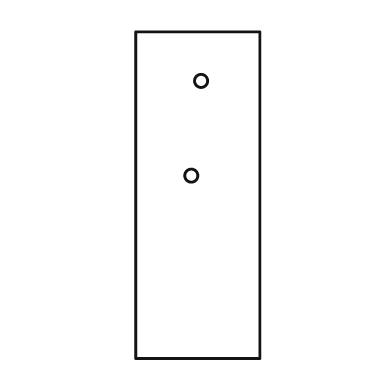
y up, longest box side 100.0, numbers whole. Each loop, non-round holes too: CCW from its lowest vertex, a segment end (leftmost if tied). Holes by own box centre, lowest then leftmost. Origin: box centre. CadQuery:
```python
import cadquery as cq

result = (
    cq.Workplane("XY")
    .moveTo(-19.0, -50.0)
    .lineTo(19.0, -50.0)
    .lineTo(19.0, 50.0)
    .lineTo(-19.0, 50.0)
    .close()
    .moveTo(-2.0, 6.0)
    .circle(2.0)
    .moveTo(1.0, 35.0)
    .circle(2.0)
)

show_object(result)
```